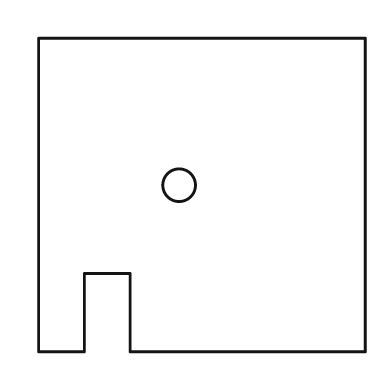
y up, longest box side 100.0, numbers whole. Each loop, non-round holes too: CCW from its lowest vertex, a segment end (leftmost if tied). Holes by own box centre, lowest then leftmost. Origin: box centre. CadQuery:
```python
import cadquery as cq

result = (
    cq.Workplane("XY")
    .moveTo(-50.0, -48.0)
    .lineTo(-36.0, -48.0)
    .lineTo(-36.0, -24.0)
    .lineTo(-22.0, -24.0)
    .lineTo(-22.0, -48.0)
    .lineTo(50.0, -48.0)
    .lineTo(50.0, 48.0)
    .lineTo(-50.0, 48.0)
    .close()
    .moveTo(-7.0, 3.0)
    .circle(5.0)
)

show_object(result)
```